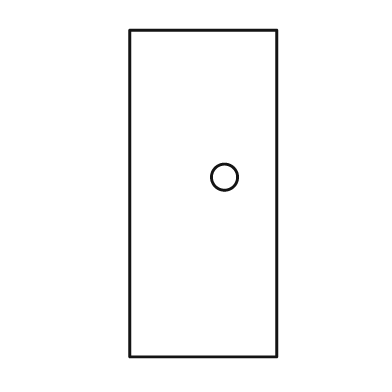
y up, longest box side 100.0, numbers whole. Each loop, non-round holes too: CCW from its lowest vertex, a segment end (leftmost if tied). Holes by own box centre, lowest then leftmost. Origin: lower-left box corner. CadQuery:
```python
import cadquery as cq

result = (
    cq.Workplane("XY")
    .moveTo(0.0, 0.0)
    .lineTo(45.0, 0.0)
    .lineTo(45.0, 100.0)
    .lineTo(0.0, 100.0)
    .close()
    .moveTo(29.0, 55.0)
    .circle(4.0)
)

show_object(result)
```